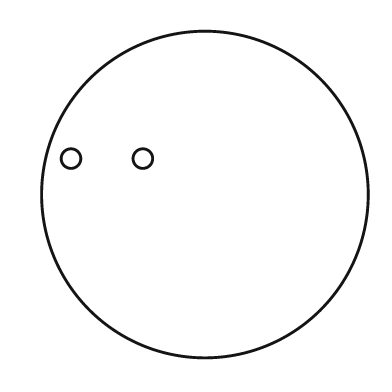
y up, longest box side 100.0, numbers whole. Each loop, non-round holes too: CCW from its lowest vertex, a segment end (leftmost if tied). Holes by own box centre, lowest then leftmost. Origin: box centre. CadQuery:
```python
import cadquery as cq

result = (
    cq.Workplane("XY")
    .moveTo(0.0, 0.0)
    .circle(50.0)
    .moveTo(-41.0, 11.0)
    .circle(3.0)
    .moveTo(-19.0, 11.0)
    .circle(3.0)
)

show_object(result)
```